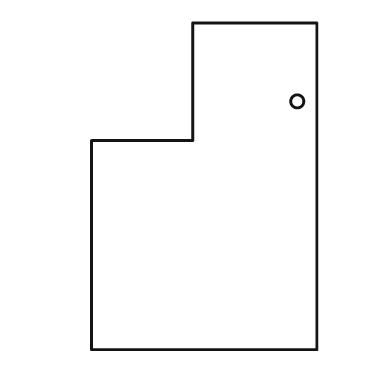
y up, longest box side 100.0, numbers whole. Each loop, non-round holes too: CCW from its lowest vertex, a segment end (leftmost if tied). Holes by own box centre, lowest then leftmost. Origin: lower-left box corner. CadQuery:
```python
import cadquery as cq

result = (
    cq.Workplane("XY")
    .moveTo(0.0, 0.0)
    .lineTo(69.0, 0.0)
    .lineTo(69.0, 100.0)
    .lineTo(31.0, 100.0)
    .lineTo(31.0, 64.0)
    .lineTo(0.0, 64.0)
    .close()
    .moveTo(63.0, 76.0)
    .circle(2.0)
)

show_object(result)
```